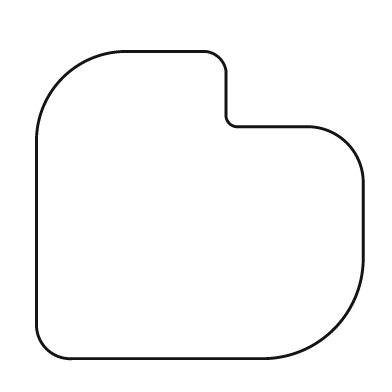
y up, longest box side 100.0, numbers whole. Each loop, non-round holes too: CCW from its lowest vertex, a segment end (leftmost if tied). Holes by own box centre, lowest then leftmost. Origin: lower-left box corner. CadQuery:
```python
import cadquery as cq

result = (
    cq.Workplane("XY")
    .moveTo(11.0, 0.0)
    .lineTo(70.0, 0.0)
    .threePointArc((91.0, 9.0), (100.0, 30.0))
    .lineTo(100.0, 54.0)
    .threePointArc((95.0, 66.0), (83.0, 71.0))
    .lineTo(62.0, 71.0)
    .threePointArc((59.0, 72.0), (58.0, 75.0))
    .lineTo(58.0, 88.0)
    .threePointArc((56.0, 92.0), (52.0, 94.0))
    .lineTo(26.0, 94.0)
    .threePointArc((8.0, 86.0), (0.0, 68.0))
    .lineTo(0.0, 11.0)
    .threePointArc((3.0, 3.0), (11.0, 0.0))
    .close()
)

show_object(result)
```